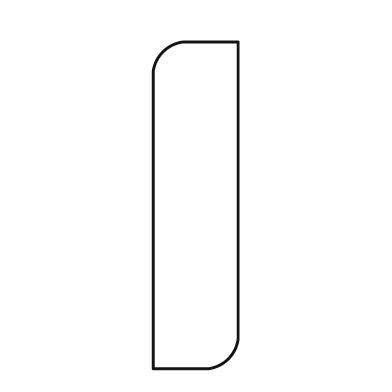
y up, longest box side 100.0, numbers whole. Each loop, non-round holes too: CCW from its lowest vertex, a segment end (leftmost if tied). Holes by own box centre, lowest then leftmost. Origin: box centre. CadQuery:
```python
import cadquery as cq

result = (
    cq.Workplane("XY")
    .moveTo(-13.0, -50.0)
    .lineTo(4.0, -50.0)
    .threePointArc((10.0, -47.0), (13.0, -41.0))
    .lineTo(13.0, 50.0)
    .lineTo(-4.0, 50.0)
    .threePointArc((-10.0, 47.0), (-13.0, 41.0))
    .close()
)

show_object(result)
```